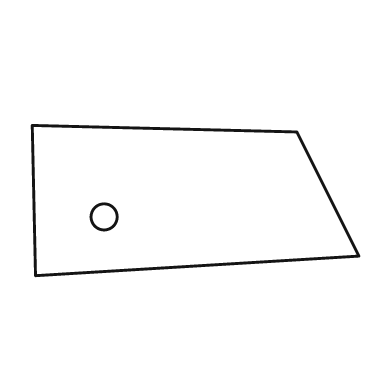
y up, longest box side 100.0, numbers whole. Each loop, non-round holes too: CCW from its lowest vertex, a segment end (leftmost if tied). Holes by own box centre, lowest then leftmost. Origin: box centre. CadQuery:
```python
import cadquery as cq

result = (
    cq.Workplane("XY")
    .moveTo(-49.0, -23.0)
    .lineTo(50.0, -17.0)
    .lineTo(31.0, 21.0)
    .lineTo(-50.0, 23.0)
    .close()
    .moveTo(-28.0, -5.0)
    .circle(4.0)
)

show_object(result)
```